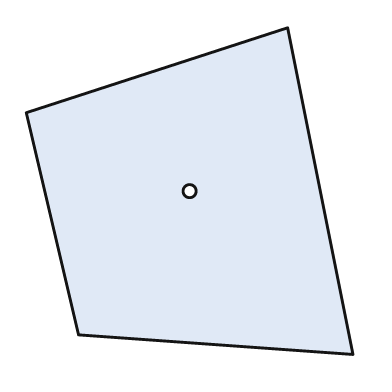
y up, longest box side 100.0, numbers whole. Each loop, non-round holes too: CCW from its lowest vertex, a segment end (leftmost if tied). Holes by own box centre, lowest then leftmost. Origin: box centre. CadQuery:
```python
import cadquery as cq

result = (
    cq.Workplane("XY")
    .moveTo(50.0, -50.0)
    .lineTo(30.0, 50.0)
    .lineTo(-50.0, 24.0)
    .lineTo(-34.0, -44.0)
    .close()
    .moveTo(0.0, 0.0)
    .circle(2.0)
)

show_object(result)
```